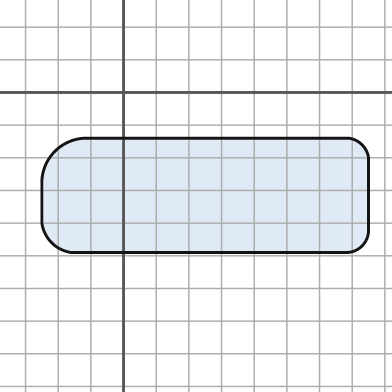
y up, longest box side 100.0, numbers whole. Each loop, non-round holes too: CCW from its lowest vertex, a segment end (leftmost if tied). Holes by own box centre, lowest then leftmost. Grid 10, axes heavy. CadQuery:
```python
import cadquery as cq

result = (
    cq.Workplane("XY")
    .moveTo(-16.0, -49.0)
    .lineTo(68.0, -49.0)
    .threePointArc((73.0, -47.0), (75.0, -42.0))
    .lineTo(75.0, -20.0)
    .threePointArc((73.0, -16.0), (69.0, -14.0))
    .lineTo(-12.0, -14.0)
    .threePointArc((-21.0, -18.0), (-25.0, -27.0))
    .lineTo(-25.0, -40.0)
    .threePointArc((-22.0, -46.0), (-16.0, -49.0))
    .close()
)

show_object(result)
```